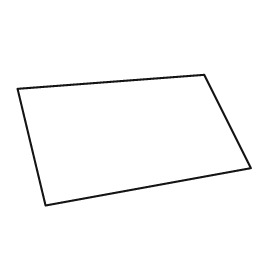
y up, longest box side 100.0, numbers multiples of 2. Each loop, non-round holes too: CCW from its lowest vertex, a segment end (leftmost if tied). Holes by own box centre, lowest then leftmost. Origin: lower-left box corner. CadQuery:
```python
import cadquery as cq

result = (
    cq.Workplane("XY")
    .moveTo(12.0, 0.0)
    .lineTo(100.0, 16.0)
    .lineTo(80.0, 56.0)
    .lineTo(0.0, 50.0)
    .close()
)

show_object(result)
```